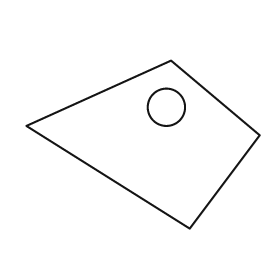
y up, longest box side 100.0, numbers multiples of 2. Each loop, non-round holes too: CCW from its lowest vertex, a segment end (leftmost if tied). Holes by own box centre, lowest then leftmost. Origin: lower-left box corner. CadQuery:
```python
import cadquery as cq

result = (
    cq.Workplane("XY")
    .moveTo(70.0, 0.0)
    .lineTo(100.0, 40.0)
    .lineTo(62.0, 72.0)
    .lineTo(0.0, 44.0)
    .close()
    .moveTo(60.0, 52.0)
    .circle(8.0)
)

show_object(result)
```